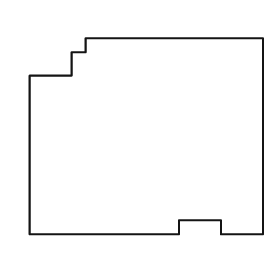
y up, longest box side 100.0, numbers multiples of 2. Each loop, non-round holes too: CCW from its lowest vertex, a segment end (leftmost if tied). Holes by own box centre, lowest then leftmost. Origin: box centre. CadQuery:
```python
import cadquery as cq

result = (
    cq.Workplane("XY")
    .moveTo(-50.0, -42.0)
    .lineTo(14.0, -42.0)
    .lineTo(14.0, -36.0)
    .lineTo(32.0, -36.0)
    .lineTo(32.0, -42.0)
    .lineTo(50.0, -42.0)
    .lineTo(50.0, 42.0)
    .lineTo(-26.0, 42.0)
    .lineTo(-26.0, 36.0)
    .lineTo(-32.0, 36.0)
    .lineTo(-32.0, 26.0)
    .lineTo(-50.0, 26.0)
    .close()
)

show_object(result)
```